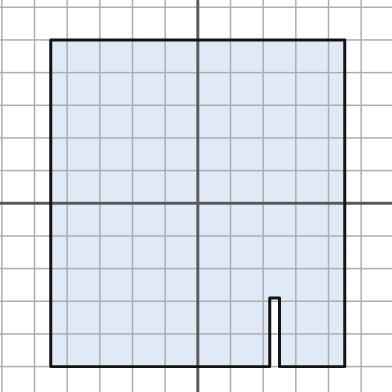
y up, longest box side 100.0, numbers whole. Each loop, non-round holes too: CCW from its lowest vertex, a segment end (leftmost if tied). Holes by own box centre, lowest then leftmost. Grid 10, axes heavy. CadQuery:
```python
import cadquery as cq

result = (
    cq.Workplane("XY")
    .moveTo(-45.0, -50.0)
    .lineTo(22.0, -50.0)
    .lineTo(22.0, -29.0)
    .lineTo(25.0, -29.0)
    .lineTo(25.0, -50.0)
    .lineTo(45.0, -50.0)
    .lineTo(45.0, 50.0)
    .lineTo(-45.0, 50.0)
    .close()
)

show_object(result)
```